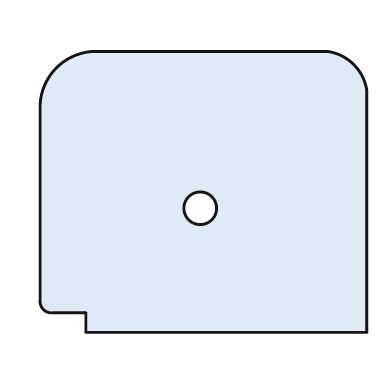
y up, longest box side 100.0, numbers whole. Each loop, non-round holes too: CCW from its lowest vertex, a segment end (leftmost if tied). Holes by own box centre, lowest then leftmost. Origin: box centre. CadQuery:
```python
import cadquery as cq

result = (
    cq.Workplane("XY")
    .moveTo(-36.0, -43.0)
    .lineTo(50.0, -43.0)
    .lineTo(50.0, 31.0)
    .threePointArc((46.0, 39.0), (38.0, 43.0))
    .lineTo(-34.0, 43.0)
    .threePointArc((-45.0, 38.0), (-50.0, 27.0))
    .lineTo(-50.0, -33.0)
    .threePointArc((-49.0, -36.0), (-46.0, -37.0))
    .lineTo(-36.0, -37.0)
    .close()
    .moveTo(-1.0, -5.0)
    .circle(5.0)
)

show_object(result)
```